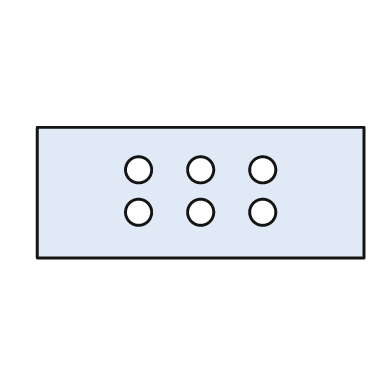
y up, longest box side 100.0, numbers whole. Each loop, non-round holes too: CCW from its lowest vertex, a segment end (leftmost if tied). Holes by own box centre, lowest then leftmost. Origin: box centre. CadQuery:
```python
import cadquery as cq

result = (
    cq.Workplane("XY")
    .moveTo(-50.0, -20.0)
    .lineTo(50.0, -20.0)
    .lineTo(50.0, 20.0)
    .lineTo(-50.0, 20.0)
    .close()
    .moveTo(-19.0, -6.0)
    .circle(4.0)
    .moveTo(0.0, -6.0)
    .circle(4.0)
    .moveTo(19.0, -6.0)
    .circle(4.0)
    .moveTo(-19.0, 7.0)
    .circle(4.0)
    .moveTo(0.0, 7.0)
    .circle(4.0)
    .moveTo(19.0, 7.0)
    .circle(4.0)
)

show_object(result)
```